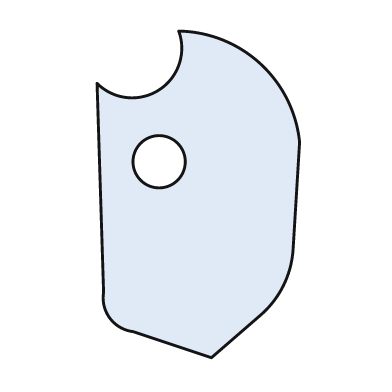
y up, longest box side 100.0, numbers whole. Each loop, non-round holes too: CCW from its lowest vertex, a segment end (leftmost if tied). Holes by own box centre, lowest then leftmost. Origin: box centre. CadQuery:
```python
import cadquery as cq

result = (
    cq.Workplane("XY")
    .moveTo(4.0, -50.0)
    .lineTo(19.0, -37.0)
    .threePointArc((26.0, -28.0), (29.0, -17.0))
    .lineTo(31.0, 16.0)
    .threePointArc((19.0, 40.0), (-6.0, 50.0))
    .threePointArc((-12.0, 32.0), (-31.0, 34.0))
    .lineTo(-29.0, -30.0)
    .threePointArc((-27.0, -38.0), (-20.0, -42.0))
    .close()
    .moveTo(-12.0, 10.0)
    .circle(8.0)
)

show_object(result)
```